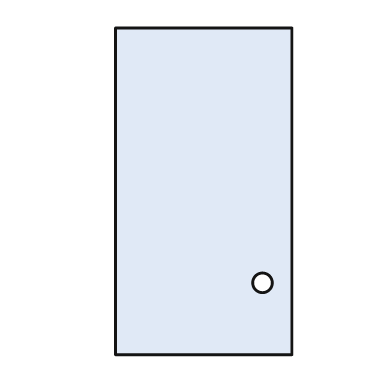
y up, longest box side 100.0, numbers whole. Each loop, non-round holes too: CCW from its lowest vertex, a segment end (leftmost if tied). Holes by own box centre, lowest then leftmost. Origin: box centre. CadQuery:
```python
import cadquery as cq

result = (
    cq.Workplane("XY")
    .moveTo(-27.0, -50.0)
    .lineTo(27.0, -50.0)
    .lineTo(27.0, 50.0)
    .lineTo(-27.0, 50.0)
    .close()
    .moveTo(18.0, -28.0)
    .circle(3.0)
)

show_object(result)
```